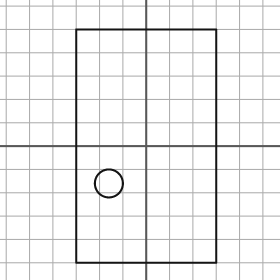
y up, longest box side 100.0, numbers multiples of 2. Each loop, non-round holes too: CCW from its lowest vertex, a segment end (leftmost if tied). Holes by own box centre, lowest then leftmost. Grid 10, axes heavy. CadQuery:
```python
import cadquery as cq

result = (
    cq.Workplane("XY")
    .moveTo(-30.0, -50.0)
    .lineTo(30.0, -50.0)
    .lineTo(30.0, 50.0)
    .lineTo(-30.0, 50.0)
    .close()
    .moveTo(-16.0, -16.0)
    .circle(6.0)
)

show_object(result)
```